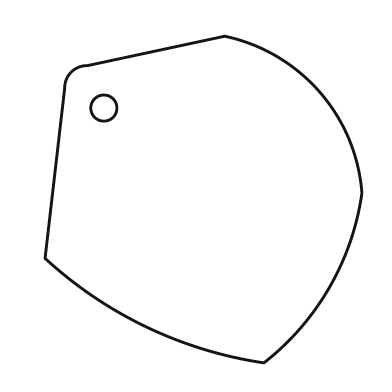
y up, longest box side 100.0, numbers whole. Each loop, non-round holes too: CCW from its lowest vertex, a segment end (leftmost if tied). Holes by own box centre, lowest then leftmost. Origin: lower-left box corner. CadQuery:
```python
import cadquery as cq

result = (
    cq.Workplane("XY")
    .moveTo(67.0, 0.0)
    .threePointArc((87.0, 23.0), (97.0, 52.0))
    .threePointArc((84.0, 83.0), (55.0, 100.0))
    .lineTo(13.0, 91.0)
    .threePointArc((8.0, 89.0), (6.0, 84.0))
    .lineTo(0.0, 32.0)
    .threePointArc((31.0, 11.0), (67.0, 0.0))
    .close()
    .moveTo(18.0, 78.0)
    .circle(4.0)
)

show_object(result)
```